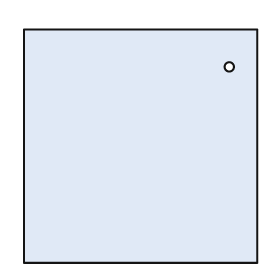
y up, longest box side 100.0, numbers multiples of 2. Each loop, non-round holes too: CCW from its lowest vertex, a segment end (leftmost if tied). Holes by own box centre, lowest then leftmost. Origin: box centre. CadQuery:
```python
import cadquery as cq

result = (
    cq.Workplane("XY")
    .moveTo(-50.0, -50.0)
    .lineTo(50.0, -50.0)
    .lineTo(50.0, 50.0)
    .lineTo(-50.0, 50.0)
    .close()
    .moveTo(38.0, 34.0)
    .circle(2.0)
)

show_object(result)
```